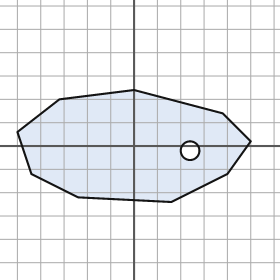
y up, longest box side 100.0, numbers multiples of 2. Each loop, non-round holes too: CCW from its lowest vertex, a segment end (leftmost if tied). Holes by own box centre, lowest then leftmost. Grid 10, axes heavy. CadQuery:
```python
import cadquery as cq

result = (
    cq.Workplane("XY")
    .moveTo(16.0, -24.0)
    .lineTo(40.0, -12.0)
    .lineTo(50.0, 2.0)
    .lineTo(38.0, 14.0)
    .lineTo(0.0, 24.0)
    .lineTo(-32.0, 20.0)
    .lineTo(-50.0, 6.0)
    .lineTo(-44.0, -12.0)
    .lineTo(-24.0, -22.0)
    .close()
    .moveTo(24.0, -2.0)
    .circle(4.0)
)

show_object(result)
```